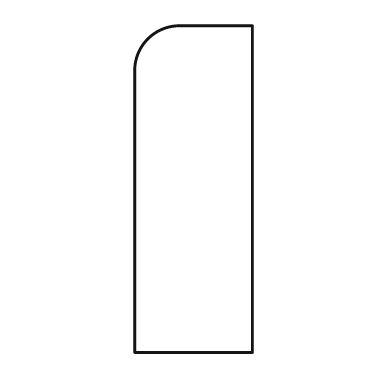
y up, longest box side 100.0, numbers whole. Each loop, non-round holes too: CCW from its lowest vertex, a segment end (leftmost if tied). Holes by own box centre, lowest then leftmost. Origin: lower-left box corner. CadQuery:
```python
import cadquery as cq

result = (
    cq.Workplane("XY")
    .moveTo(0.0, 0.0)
    .lineTo(36.0, 0.0)
    .lineTo(36.0, 100.0)
    .lineTo(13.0, 100.0)
    .threePointArc((4.0, 96.0), (0.0, 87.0))
    .close()
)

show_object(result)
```